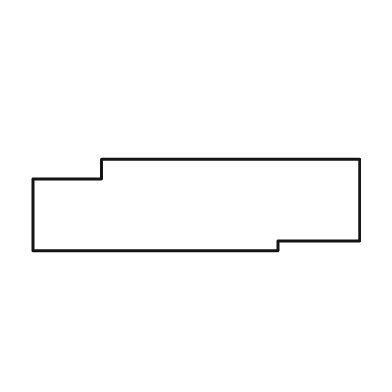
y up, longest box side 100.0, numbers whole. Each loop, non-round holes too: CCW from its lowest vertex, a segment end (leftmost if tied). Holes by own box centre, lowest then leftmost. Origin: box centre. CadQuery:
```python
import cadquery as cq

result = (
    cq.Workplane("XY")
    .moveTo(-50.0, -14.0)
    .lineTo(25.0, -14.0)
    .lineTo(25.0, -11.0)
    .lineTo(50.0, -11.0)
    .lineTo(50.0, 14.0)
    .lineTo(-29.0, 14.0)
    .lineTo(-29.0, 8.0)
    .lineTo(-50.0, 8.0)
    .close()
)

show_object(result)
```